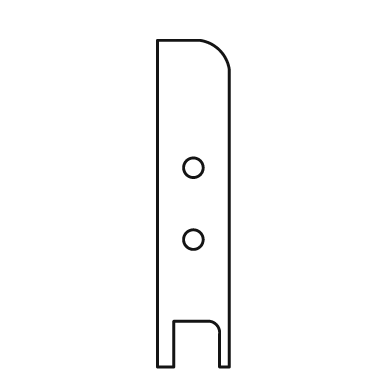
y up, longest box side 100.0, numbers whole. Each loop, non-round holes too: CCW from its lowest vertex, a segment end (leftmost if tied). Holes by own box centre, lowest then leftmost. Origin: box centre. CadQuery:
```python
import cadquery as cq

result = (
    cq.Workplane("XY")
    .moveTo(-11.0, -50.0)
    .lineTo(-6.0, -50.0)
    .lineTo(-6.0, -36.0)
    .lineTo(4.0, -36.0)
    .threePointArc((7.0, -37.0), (8.0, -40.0))
    .lineTo(8.0, -50.0)
    .lineTo(11.0, -50.0)
    .lineTo(11.0, 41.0)
    .threePointArc((8.0, 47.0), (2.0, 50.0))
    .lineTo(-11.0, 50.0)
    .close()
    .moveTo(0.0, -11.0)
    .circle(3.0)
    .moveTo(0.0, 11.0)
    .circle(3.0)
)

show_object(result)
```